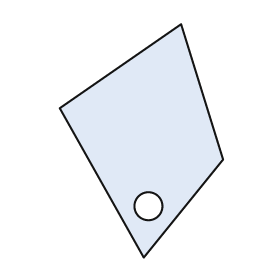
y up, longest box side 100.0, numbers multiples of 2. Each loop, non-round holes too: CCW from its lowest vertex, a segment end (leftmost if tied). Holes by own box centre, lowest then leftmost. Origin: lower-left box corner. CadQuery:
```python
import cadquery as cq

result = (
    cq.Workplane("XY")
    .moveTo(36.0, 0.0)
    .lineTo(70.0, 42.0)
    .lineTo(52.0, 100.0)
    .lineTo(0.0, 64.0)
    .close()
    .moveTo(38.0, 22.0)
    .circle(6.0)
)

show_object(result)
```